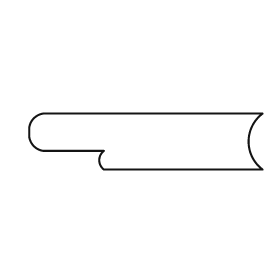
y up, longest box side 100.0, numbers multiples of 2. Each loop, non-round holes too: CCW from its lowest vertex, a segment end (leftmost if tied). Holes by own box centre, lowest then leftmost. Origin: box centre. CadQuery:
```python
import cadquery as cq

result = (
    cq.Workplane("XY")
    .moveTo(-18.0, -12.0)
    .lineTo(50.0, -12.0)
    .threePointArc((44.0, 0.0), (50.0, 12.0))
    .lineTo(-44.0, 12.0)
    .threePointArc((-48.0, 10.0), (-50.0, 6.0))
    .lineTo(-50.0, 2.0)
    .threePointArc((-48.0, -2.0), (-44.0, -4.0))
    .lineTo(-18.0, -4.0)
    .threePointArc((-20.0, -8.0), (-18.0, -12.0))
    .close()
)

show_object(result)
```